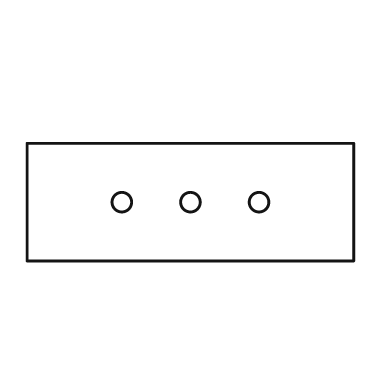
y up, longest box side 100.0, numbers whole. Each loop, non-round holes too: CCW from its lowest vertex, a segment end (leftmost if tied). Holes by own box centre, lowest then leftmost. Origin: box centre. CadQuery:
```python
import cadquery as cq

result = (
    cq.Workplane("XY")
    .moveTo(-50.0, -18.0)
    .lineTo(50.0, -18.0)
    .lineTo(50.0, 18.0)
    .lineTo(-50.0, 18.0)
    .close()
    .moveTo(-21.0, 0.0)
    .circle(3.0)
    .moveTo(0.0, 0.0)
    .circle(3.0)
    .moveTo(21.0, 0.0)
    .circle(3.0)
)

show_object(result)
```